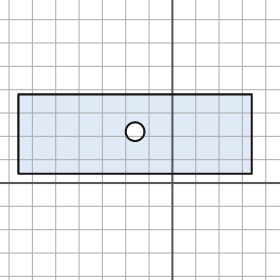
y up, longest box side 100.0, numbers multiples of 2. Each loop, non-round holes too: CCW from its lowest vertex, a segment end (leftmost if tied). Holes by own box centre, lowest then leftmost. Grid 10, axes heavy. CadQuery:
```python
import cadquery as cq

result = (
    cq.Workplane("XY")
    .moveTo(-66.0, 4.0)
    .lineTo(34.0, 4.0)
    .lineTo(34.0, 38.0)
    .lineTo(-66.0, 38.0)
    .close()
    .moveTo(-16.0, 22.0)
    .circle(4.0)
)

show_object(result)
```